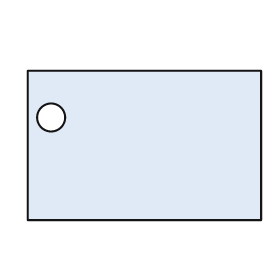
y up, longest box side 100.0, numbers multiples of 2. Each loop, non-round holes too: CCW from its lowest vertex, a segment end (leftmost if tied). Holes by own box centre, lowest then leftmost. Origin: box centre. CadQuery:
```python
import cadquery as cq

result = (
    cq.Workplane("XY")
    .moveTo(-50.0, -32.0)
    .lineTo(50.0, -32.0)
    .lineTo(50.0, 32.0)
    .lineTo(-50.0, 32.0)
    .close()
    .moveTo(-40.0, 12.0)
    .circle(6.0)
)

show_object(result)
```